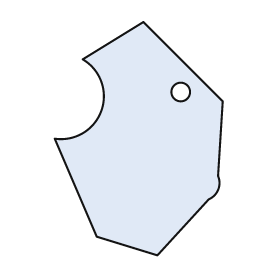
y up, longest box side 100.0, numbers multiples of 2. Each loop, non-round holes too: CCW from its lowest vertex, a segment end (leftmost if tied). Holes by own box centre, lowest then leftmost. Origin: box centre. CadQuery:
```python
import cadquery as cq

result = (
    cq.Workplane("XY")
    .moveTo(8.0, -50.0)
    .lineTo(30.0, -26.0)
    .threePointArc((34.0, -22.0), (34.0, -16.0))
    .lineTo(36.0, 16.0)
    .lineTo(2.0, 50.0)
    .lineTo(-24.0, 34.0)
    .threePointArc((-16.0, 12.0), (-36.0, 0.0))
    .lineTo(-18.0, -42.0)
    .close()
    .moveTo(18.0, 20.0)
    .circle(4.0)
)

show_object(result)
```